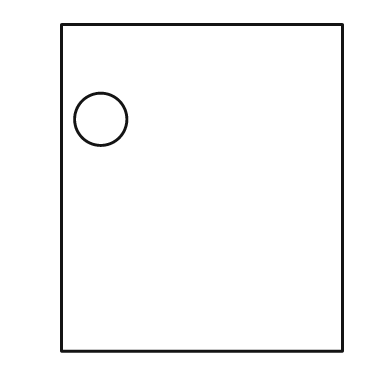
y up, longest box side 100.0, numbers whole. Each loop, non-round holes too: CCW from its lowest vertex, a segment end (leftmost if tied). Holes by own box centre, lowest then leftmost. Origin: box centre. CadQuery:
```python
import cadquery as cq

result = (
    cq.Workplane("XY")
    .moveTo(-43.0, -50.0)
    .lineTo(43.0, -50.0)
    .lineTo(43.0, 50.0)
    .lineTo(-43.0, 50.0)
    .close()
    .moveTo(-31.0, 21.0)
    .circle(8.0)
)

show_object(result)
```